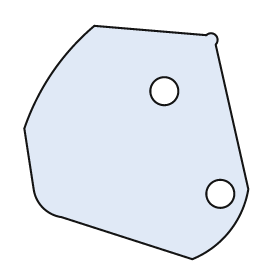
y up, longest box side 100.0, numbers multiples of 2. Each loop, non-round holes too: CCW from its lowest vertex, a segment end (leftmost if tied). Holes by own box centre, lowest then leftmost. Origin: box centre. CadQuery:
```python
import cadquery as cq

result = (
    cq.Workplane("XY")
    .moveTo(24.0, -50.0)
    .threePointArc((40.0, -38.0), (48.0, -20.0))
    .lineTo(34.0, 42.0)
    .threePointArc((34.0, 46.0), (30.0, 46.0))
    .lineTo(-18.0, 50.0)
    .threePointArc((-36.0, 30.0), (-48.0, 6.0))
    .lineTo(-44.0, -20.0)
    .threePointArc((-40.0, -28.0), (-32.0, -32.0))
    .close()
    .moveTo(36.0, -22.0)
    .circle(6.0)
    .moveTo(12.0, 22.0)
    .circle(6.0)
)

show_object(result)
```